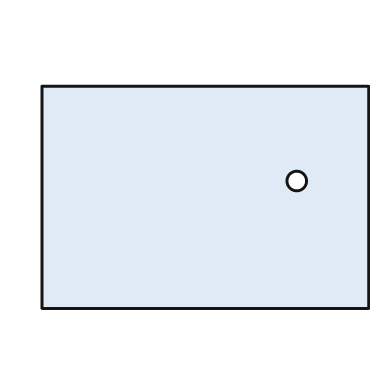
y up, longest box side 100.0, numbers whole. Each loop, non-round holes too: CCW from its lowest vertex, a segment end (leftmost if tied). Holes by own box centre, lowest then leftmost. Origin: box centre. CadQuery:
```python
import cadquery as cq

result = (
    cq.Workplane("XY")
    .moveTo(-50.0, -34.0)
    .lineTo(50.0, -34.0)
    .lineTo(50.0, 34.0)
    .lineTo(-50.0, 34.0)
    .close()
    .moveTo(28.0, 5.0)
    .circle(3.0)
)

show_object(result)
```